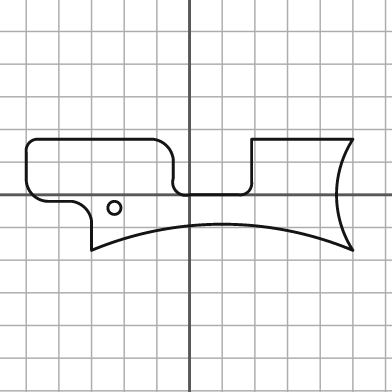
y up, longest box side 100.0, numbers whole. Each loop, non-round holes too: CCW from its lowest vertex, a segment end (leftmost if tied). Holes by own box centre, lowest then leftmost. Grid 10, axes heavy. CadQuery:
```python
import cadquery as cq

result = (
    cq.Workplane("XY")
    .moveTo(-30.0, -17.0)
    .threePointArc((10.0, -9.0), (50.0, -17.0))
    .threePointArc((45.0, 0.0), (50.0, 17.0))
    .lineTo(19.0, 17.0)
    .lineTo(19.0, 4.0)
    .threePointArc((18.0, 1.0), (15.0, 0.0))
    .lineTo(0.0, 0.0)
    .threePointArc((-4.0, 1.0), (-5.0, 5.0))
    .lineTo(-5.0, 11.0)
    .threePointArc((-7.0, 15.0), (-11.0, 17.0))
    .lineTo(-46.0, 17.0)
    .threePointArc((-49.0, 16.0), (-50.0, 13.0))
    .lineTo(-50.0, 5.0)
    .threePointArc((-48.0, 0.0), (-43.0, -2.0))
    .lineTo(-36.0, -2.0)
    .threePointArc((-32.0, -4.0), (-30.0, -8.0))
    .close()
    .moveTo(-23.0, -4.0)
    .circle(2.0)
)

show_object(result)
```